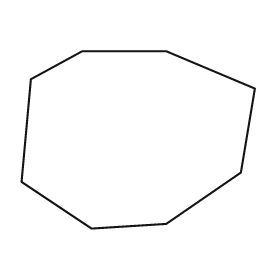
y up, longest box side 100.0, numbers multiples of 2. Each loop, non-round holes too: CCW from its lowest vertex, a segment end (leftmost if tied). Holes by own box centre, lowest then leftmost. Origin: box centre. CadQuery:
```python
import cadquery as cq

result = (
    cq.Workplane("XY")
    .moveTo(-20.0, -38.0)
    .lineTo(12.0, -36.0)
    .lineTo(44.0, -14.0)
    .lineTo(50.0, 22.0)
    .lineTo(12.0, 38.0)
    .lineTo(-24.0, 38.0)
    .lineTo(-46.0, 26.0)
    .lineTo(-50.0, -18.0)
    .close()
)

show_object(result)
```